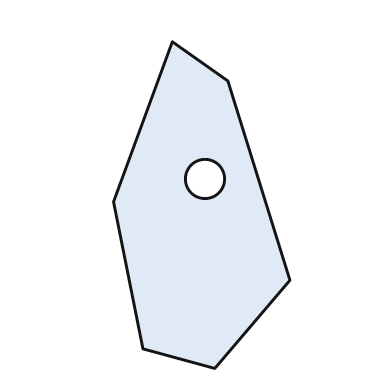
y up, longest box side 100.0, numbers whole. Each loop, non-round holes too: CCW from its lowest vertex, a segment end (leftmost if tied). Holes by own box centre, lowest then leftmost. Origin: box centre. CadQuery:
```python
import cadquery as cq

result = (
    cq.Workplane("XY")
    .moveTo(4.0, -50.0)
    .lineTo(27.0, -23.0)
    .lineTo(8.0, 38.0)
    .lineTo(-9.0, 50.0)
    .lineTo(-27.0, 1.0)
    .lineTo(-18.0, -44.0)
    .close()
    .moveTo(1.0, 8.0)
    .circle(6.0)
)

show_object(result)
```